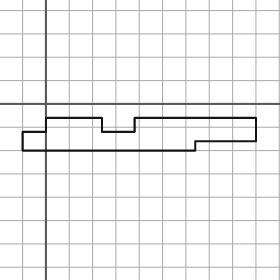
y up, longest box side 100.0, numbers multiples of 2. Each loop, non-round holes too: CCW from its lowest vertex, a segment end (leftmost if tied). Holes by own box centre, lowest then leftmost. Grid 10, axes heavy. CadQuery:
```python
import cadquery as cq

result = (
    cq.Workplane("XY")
    .moveTo(-10.0, -20.0)
    .lineTo(64.0, -20.0)
    .lineTo(64.0, -16.0)
    .lineTo(90.0, -16.0)
    .lineTo(90.0, -6.0)
    .lineTo(38.0, -6.0)
    .lineTo(38.0, -12.0)
    .lineTo(24.0, -12.0)
    .lineTo(24.0, -6.0)
    .lineTo(0.0, -6.0)
    .lineTo(0.0, -12.0)
    .lineTo(-10.0, -12.0)
    .close()
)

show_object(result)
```